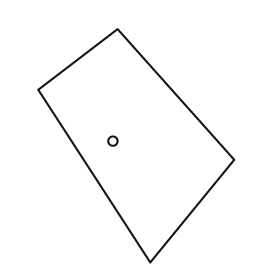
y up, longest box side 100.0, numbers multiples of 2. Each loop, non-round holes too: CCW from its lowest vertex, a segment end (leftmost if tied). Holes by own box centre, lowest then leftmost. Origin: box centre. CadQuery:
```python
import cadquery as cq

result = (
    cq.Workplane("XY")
    .moveTo(6.0, -50.0)
    .lineTo(42.0, -6.0)
    .lineTo(-8.0, 50.0)
    .lineTo(-42.0, 24.0)
    .close()
    .moveTo(-10.0, 2.0)
    .circle(2.0)
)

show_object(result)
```